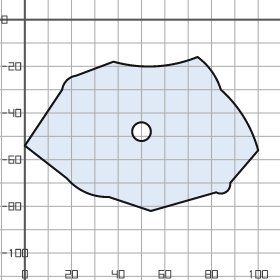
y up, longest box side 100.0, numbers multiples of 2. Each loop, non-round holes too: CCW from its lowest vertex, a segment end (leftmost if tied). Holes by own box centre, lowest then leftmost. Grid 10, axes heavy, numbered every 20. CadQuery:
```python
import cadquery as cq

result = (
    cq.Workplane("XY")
    .moveTo(54.0, -82.0)
    .lineTo(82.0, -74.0)
    .threePointArc((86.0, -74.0), (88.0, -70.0))
    .lineTo(100.0, -56.0)
    .threePointArc((94.0, -42.0), (84.0, -30.0))
    .threePointArc((80.0, -22.0), (74.0, -16.0))
    .threePointArc((56.0, -20.0), (38.0, -18.0))
    .lineTo(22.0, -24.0)
    .threePointArc((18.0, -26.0), (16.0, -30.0))
    .lineTo(0.0, -54.0)
    .lineTo(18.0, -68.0)
    .threePointArc((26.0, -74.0), (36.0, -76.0))
    .close()
    .moveTo(50.0, -48.0)
    .circle(4.0)
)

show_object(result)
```